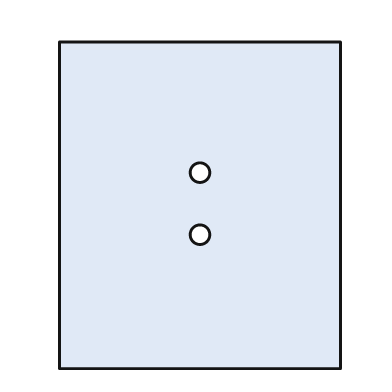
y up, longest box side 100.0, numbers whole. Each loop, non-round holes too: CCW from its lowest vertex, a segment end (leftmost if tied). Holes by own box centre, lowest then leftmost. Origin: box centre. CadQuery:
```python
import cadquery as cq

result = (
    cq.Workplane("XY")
    .moveTo(-43.0, -50.0)
    .lineTo(43.0, -50.0)
    .lineTo(43.0, 50.0)
    .lineTo(-43.0, 50.0)
    .close()
    .moveTo(0.0, -9.0)
    .circle(3.0)
    .moveTo(0.0, 10.0)
    .circle(3.0)
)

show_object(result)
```